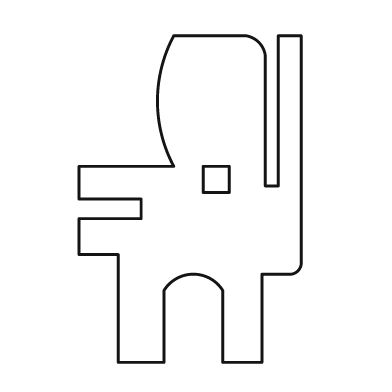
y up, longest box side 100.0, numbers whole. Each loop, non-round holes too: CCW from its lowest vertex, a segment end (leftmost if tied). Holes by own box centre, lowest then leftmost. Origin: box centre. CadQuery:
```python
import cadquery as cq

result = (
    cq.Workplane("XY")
    .moveTo(-22.0, -50.0)
    .lineTo(-8.0, -50.0)
    .lineTo(-8.0, -28.0)
    .threePointArc((1.0, -23.0), (10.0, -28.0))
    .lineTo(10.0, -50.0)
    .lineTo(22.0, -50.0)
    .lineTo(22.0, -23.0)
    .lineTo(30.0, -23.0)
    .threePointArc((33.0, -22.0), (34.0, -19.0))
    .lineTo(34.0, 50.0)
    .lineTo(27.0, 50.0)
    .lineTo(27.0, 4.0)
    .lineTo(23.0, 4.0)
    .lineTo(23.0, 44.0)
    .threePointArc((21.0, 48.0), (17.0, 50.0))
    .lineTo(-5.0, 50.0)
    .threePointArc((-10.0, 30.0), (-5.0, 10.0))
    .lineTo(-34.0, 10.0)
    .lineTo(-34.0, 0.0)
    .lineTo(-15.0, 0.0)
    .lineTo(-15.0, -6.0)
    .lineTo(-34.0, -6.0)
    .lineTo(-34.0, -17.0)
    .lineTo(-22.0, -17.0)
    .close()
    .moveTo(4.0, 2.0)
    .lineTo(12.0, 2.0)
    .lineTo(12.0, 10.0)
    .lineTo(4.0, 10.0)
    .close()
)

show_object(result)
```